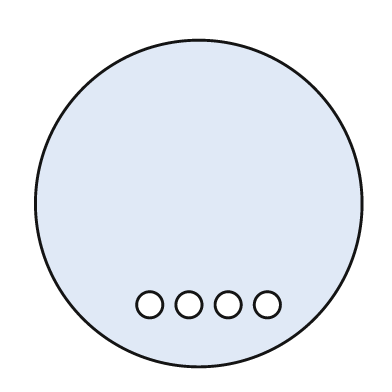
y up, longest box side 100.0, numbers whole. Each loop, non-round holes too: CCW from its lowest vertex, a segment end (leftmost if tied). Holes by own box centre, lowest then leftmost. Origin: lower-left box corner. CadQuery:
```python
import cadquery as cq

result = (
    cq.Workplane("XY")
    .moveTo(50.0, 50.0)
    .circle(50.0)
    .moveTo(35.0, 19.0)
    .circle(4.0)
    .moveTo(47.0, 19.0)
    .circle(4.0)
    .moveTo(59.0, 19.0)
    .circle(4.0)
    .moveTo(71.0, 19.0)
    .circle(4.0)
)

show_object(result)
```